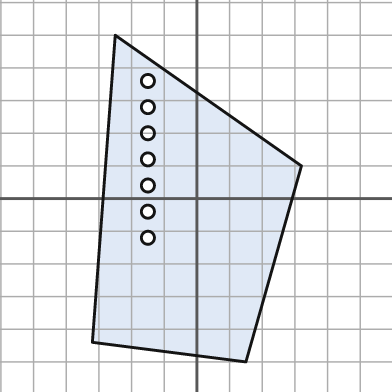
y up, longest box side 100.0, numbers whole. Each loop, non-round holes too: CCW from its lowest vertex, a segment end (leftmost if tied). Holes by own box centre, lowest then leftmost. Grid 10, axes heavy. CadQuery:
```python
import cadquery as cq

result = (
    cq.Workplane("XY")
    .moveTo(15.0, -50.0)
    .lineTo(32.0, 10.0)
    .lineTo(-25.0, 50.0)
    .lineTo(-32.0, -44.0)
    .close()
    .moveTo(-15.0, -12.0)
    .circle(2.0)
    .moveTo(-15.0, -4.0)
    .circle(2.0)
    .moveTo(-15.0, 4.0)
    .circle(2.0)
    .moveTo(-15.0, 12.0)
    .circle(2.0)
    .moveTo(-15.0, 20.0)
    .circle(2.0)
    .moveTo(-15.0, 28.0)
    .circle(2.0)
    .moveTo(-15.0, 36.0)
    .circle(2.0)
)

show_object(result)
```